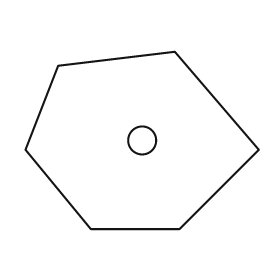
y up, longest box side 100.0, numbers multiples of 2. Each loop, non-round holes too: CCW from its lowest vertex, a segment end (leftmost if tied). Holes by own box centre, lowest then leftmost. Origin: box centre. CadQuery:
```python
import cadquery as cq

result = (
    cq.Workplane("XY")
    .moveTo(-22.0, -38.0)
    .lineTo(16.0, -38.0)
    .lineTo(50.0, -4.0)
    .lineTo(14.0, 38.0)
    .lineTo(-36.0, 32.0)
    .lineTo(-50.0, -4.0)
    .close()
    .moveTo(0.0, 0.0)
    .circle(6.0)
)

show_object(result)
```